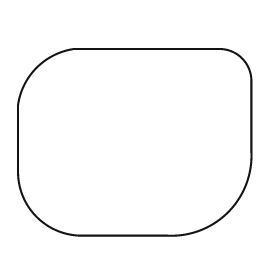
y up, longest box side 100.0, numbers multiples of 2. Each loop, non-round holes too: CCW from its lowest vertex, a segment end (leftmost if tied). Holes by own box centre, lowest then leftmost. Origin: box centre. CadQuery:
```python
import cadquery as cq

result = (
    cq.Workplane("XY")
    .moveTo(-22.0, -40.0)
    .lineTo(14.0, -40.0)
    .threePointArc((40.0, -30.0), (50.0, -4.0))
    .lineTo(50.0, 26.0)
    .threePointArc((46.0, 36.0), (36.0, 40.0))
    .lineTo(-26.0, 40.0)
    .threePointArc((-42.0, 32.0), (-50.0, 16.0))
    .lineTo(-50.0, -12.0)
    .threePointArc((-42.0, -32.0), (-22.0, -40.0))
    .close()
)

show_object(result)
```